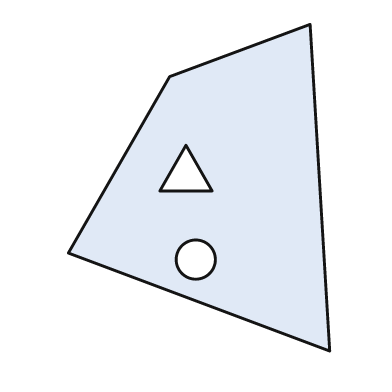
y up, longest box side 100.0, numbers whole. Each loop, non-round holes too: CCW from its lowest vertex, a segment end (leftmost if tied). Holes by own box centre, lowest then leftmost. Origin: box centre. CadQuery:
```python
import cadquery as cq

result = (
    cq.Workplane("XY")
    .moveTo(40.0, -50.0)
    .lineTo(34.0, 50.0)
    .lineTo(-9.0, 34.0)
    .lineTo(-40.0, -20.0)
    .close()
    .moveTo(-1.0, -22.0)
    .circle(6.0)
    .moveTo(-12.0, -1.0)
    .lineTo(4.0, -1.0)
    .lineTo(-4.0, 13.0)
    .close()
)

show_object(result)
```